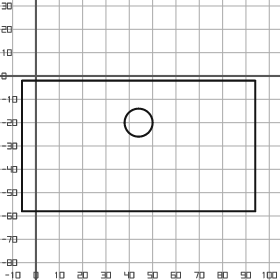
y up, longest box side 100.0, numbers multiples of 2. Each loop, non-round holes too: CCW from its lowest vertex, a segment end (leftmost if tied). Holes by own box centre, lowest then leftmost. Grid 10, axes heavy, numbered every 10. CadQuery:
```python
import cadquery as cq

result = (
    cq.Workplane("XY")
    .moveTo(-6.0, -58.0)
    .lineTo(94.0, -58.0)
    .lineTo(94.0, -2.0)
    .lineTo(-6.0, -2.0)
    .close()
    .moveTo(44.0, -20.0)
    .circle(6.0)
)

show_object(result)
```